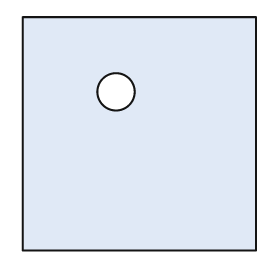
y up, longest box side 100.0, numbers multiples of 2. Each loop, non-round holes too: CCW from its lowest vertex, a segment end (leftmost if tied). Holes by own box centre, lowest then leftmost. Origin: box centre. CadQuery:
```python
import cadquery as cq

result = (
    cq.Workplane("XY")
    .moveTo(-50.0, -50.0)
    .lineTo(50.0, -50.0)
    .lineTo(50.0, 50.0)
    .lineTo(-50.0, 50.0)
    .close()
    .moveTo(-10.0, 18.0)
    .circle(8.0)
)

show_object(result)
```